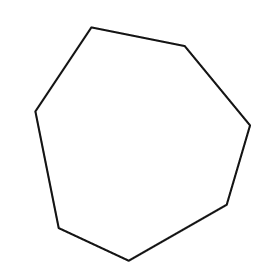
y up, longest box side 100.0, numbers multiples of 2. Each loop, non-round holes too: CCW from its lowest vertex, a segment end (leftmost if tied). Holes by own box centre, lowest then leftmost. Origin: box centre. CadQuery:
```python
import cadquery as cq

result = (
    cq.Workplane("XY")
    .moveTo(-6.0, -50.0)
    .lineTo(36.0, -26.0)
    .lineTo(46.0, 8.0)
    .lineTo(18.0, 42.0)
    .lineTo(-22.0, 50.0)
    .lineTo(-46.0, 14.0)
    .lineTo(-36.0, -36.0)
    .close()
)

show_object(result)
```